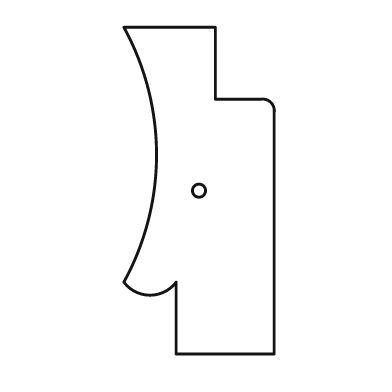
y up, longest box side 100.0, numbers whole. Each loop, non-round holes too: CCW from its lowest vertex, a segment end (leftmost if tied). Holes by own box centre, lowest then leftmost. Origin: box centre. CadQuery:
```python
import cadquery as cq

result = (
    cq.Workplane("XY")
    .moveTo(-7.0, -50.0)
    .lineTo(23.0, -50.0)
    .lineTo(23.0, 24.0)
    .threePointArc((22.0, 27.0), (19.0, 28.0))
    .lineTo(5.0, 28.0)
    .lineTo(5.0, 50.0)
    .lineTo(-23.0, 50.0)
    .threePointArc((-13.0, 11.0), (-23.0, -28.0))
    .threePointArc((-15.0, -32.0), (-7.0, -28.0))
    .close()
    .moveTo(0.0, 0.0)
    .circle(2.0)
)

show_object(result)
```